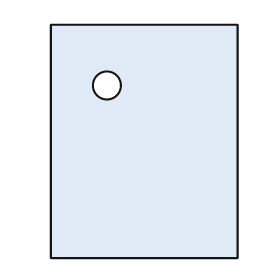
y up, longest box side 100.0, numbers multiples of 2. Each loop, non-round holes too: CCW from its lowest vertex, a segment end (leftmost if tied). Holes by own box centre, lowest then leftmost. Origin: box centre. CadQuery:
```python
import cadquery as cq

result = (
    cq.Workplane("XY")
    .moveTo(-40.0, -50.0)
    .lineTo(40.0, -50.0)
    .lineTo(40.0, 50.0)
    .lineTo(-40.0, 50.0)
    .close()
    .moveTo(-16.0, 24.0)
    .circle(6.0)
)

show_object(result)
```